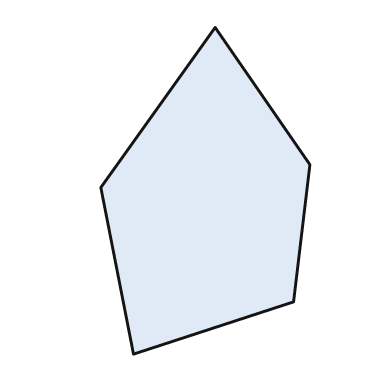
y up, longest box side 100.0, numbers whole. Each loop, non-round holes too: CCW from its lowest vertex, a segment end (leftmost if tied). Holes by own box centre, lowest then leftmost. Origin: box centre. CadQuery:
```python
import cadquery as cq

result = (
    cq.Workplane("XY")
    .moveTo(-22.0, -50.0)
    .lineTo(27.0, -34.0)
    .lineTo(32.0, 8.0)
    .lineTo(3.0, 50.0)
    .lineTo(-32.0, 1.0)
    .close()
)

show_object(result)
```